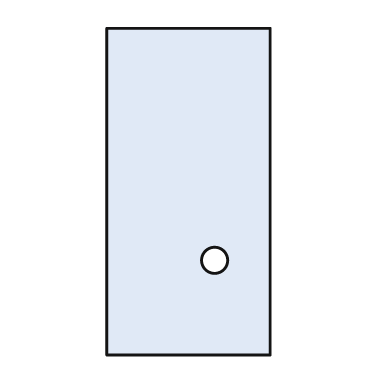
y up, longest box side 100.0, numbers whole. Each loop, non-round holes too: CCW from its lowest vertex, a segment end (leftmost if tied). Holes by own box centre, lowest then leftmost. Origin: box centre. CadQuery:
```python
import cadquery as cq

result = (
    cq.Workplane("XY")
    .moveTo(-25.0, -50.0)
    .lineTo(25.0, -50.0)
    .lineTo(25.0, 50.0)
    .lineTo(-25.0, 50.0)
    .close()
    .moveTo(8.0, -21.0)
    .circle(4.0)
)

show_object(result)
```